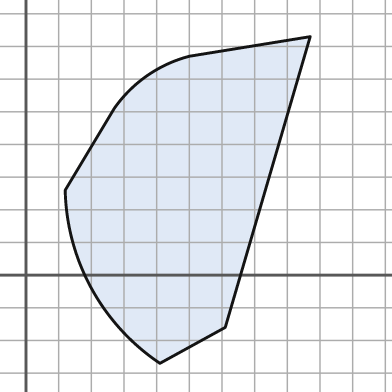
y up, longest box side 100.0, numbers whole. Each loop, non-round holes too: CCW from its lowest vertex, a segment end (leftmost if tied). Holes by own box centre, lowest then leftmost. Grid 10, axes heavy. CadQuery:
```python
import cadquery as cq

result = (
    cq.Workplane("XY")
    .moveTo(41.0, -27.0)
    .lineTo(61.0, -16.0)
    .lineTo(87.0, 73.0)
    .lineTo(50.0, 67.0)
    .threePointArc((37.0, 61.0), (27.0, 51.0))
    .lineTo(12.0, 26.0)
    .threePointArc((20.0, -4.0), (41.0, -27.0))
    .close()
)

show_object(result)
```